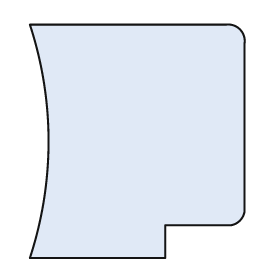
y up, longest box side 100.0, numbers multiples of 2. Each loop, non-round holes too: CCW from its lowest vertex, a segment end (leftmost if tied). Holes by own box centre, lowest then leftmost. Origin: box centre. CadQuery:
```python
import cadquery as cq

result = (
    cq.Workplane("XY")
    .moveTo(-46.0, -50.0)
    .lineTo(12.0, -50.0)
    .lineTo(12.0, -36.0)
    .lineTo(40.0, -36.0)
    .threePointArc((44.0, -34.0), (46.0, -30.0))
    .lineTo(46.0, 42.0)
    .threePointArc((44.0, 48.0), (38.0, 50.0))
    .lineTo(-46.0, 50.0)
    .threePointArc((-38.0, 0.0), (-46.0, -50.0))
    .close()
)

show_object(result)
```